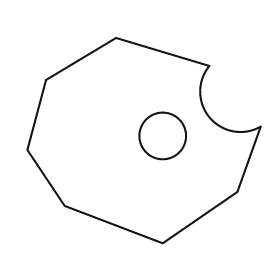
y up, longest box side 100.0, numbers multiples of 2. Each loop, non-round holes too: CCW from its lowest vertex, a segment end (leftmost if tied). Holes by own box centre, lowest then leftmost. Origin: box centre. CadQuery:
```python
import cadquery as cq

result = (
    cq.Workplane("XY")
    .moveTo(8.0, -44.0)
    .lineTo(40.0, -22.0)
    .lineTo(50.0, 6.0)
    .threePointArc((28.0, 10.0), (28.0, 32.0))
    .lineTo(-12.0, 44.0)
    .lineTo(-42.0, 26.0)
    .lineTo(-50.0, -4.0)
    .lineTo(-34.0, -28.0)
    .close()
    .moveTo(8.0, 2.0)
    .circle(10.0)
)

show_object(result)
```